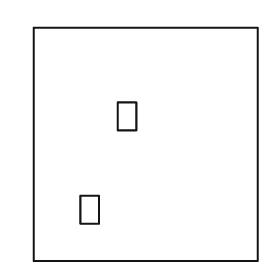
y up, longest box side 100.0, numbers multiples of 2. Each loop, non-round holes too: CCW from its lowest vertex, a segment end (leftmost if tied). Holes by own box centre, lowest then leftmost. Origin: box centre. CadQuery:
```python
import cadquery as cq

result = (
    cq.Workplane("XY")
    .moveTo(-48.0, -50.0)
    .lineTo(48.0, -50.0)
    .lineTo(48.0, 50.0)
    .lineTo(-48.0, 50.0)
    .close()
    .moveTo(-28.0, -34.0)
    .lineTo(-20.0, -34.0)
    .lineTo(-20.0, -22.0)
    .lineTo(-28.0, -22.0)
    .close()
    .moveTo(-12.0, 6.0)
    .lineTo(-4.0, 6.0)
    .lineTo(-4.0, 18.0)
    .lineTo(-12.0, 18.0)
    .close()
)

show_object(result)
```